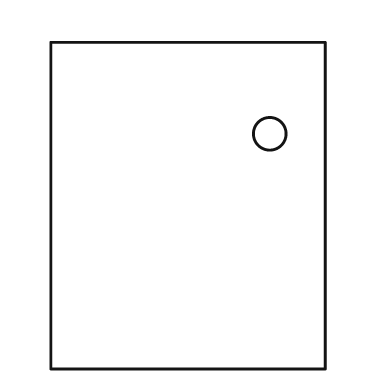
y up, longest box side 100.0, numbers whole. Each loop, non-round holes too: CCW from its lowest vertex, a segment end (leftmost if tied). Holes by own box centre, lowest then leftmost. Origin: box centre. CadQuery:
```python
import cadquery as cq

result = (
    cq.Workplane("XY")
    .moveTo(-42.0, -50.0)
    .lineTo(42.0, -50.0)
    .lineTo(42.0, 50.0)
    .lineTo(-42.0, 50.0)
    .close()
    .moveTo(25.0, 22.0)
    .circle(5.0)
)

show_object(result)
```